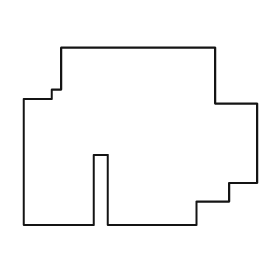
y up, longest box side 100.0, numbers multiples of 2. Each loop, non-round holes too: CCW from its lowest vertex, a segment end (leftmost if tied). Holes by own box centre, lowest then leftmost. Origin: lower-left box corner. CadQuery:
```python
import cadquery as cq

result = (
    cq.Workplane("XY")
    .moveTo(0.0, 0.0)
    .lineTo(30.0, 0.0)
    .lineTo(30.0, 30.0)
    .lineTo(36.0, 30.0)
    .lineTo(36.0, 0.0)
    .lineTo(74.0, 0.0)
    .lineTo(74.0, 10.0)
    .lineTo(88.0, 10.0)
    .lineTo(88.0, 18.0)
    .lineTo(100.0, 18.0)
    .lineTo(100.0, 52.0)
    .lineTo(82.0, 52.0)
    .lineTo(82.0, 76.0)
    .lineTo(16.0, 76.0)
    .lineTo(16.0, 58.0)
    .lineTo(12.0, 58.0)
    .lineTo(12.0, 54.0)
    .lineTo(0.0, 54.0)
    .close()
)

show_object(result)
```